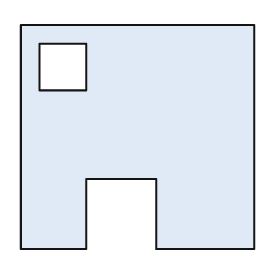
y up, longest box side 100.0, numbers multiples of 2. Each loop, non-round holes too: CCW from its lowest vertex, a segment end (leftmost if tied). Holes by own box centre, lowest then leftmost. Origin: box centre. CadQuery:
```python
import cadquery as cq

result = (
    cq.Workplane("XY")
    .moveTo(-50.0, -48.0)
    .lineTo(-22.0, -48.0)
    .lineTo(-22.0, -18.0)
    .lineTo(8.0, -18.0)
    .lineTo(8.0, -48.0)
    .lineTo(50.0, -48.0)
    .lineTo(50.0, 48.0)
    .lineTo(-50.0, 48.0)
    .close()
    .moveTo(-42.0, 20.0)
    .lineTo(-22.0, 20.0)
    .lineTo(-22.0, 40.0)
    .lineTo(-42.0, 40.0)
    .close()
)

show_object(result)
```